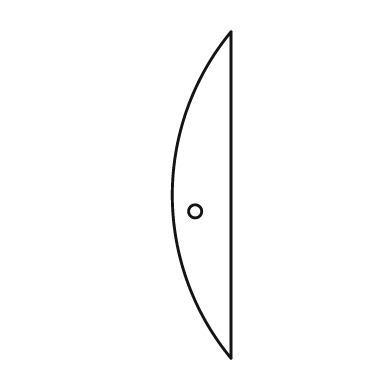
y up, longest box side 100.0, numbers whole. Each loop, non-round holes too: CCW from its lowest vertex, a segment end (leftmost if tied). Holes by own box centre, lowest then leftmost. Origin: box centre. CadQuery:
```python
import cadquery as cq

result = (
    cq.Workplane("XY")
    .moveTo(9.0, -50.0)
    .lineTo(9.0, 50.0)
    .threePointArc((-9.0, 0.0), (9.0, -50.0))
    .close()
    .moveTo(-2.0, -5.0)
    .circle(2.0)
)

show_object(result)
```